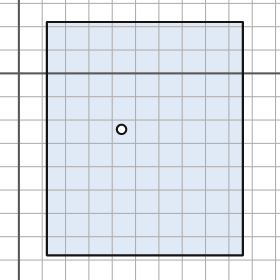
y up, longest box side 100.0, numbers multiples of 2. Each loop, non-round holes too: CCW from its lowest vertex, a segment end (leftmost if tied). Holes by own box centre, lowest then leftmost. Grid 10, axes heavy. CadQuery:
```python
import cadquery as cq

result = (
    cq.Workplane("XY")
    .moveTo(12.0, -78.0)
    .lineTo(96.0, -78.0)
    .lineTo(96.0, 22.0)
    .lineTo(12.0, 22.0)
    .close()
    .moveTo(44.0, -24.0)
    .circle(2.0)
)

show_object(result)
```